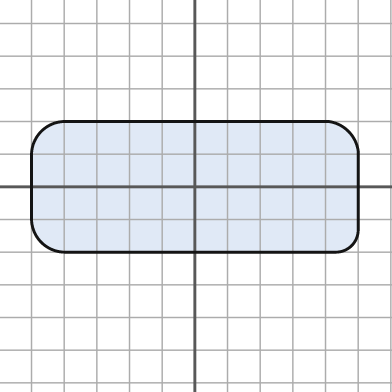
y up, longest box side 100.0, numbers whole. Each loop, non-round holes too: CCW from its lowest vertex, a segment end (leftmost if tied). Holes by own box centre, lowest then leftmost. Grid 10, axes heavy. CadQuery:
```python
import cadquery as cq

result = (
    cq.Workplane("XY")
    .moveTo(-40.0, -20.0)
    .lineTo(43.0, -20.0)
    .threePointArc((48.0, -18.0), (50.0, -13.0))
    .lineTo(50.0, 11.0)
    .threePointArc((47.0, 17.0), (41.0, 20.0))
    .lineTo(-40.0, 20.0)
    .threePointArc((-47.0, 17.0), (-50.0, 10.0))
    .lineTo(-50.0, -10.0)
    .threePointArc((-47.0, -17.0), (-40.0, -20.0))
    .close()
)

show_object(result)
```